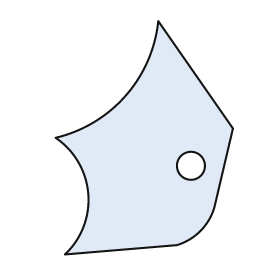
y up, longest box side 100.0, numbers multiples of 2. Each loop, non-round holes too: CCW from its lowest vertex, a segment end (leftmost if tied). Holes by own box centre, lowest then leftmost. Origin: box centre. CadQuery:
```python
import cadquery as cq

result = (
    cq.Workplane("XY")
    .moveTo(-34.0, -50.0)
    .lineTo(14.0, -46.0)
    .threePointArc((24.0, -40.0), (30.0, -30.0))
    .lineTo(38.0, 4.0)
    .lineTo(6.0, 50.0)
    .threePointArc((-8.0, 18.0), (-38.0, 0.0))
    .threePointArc((-24.0, -24.0), (-34.0, -50.0))
    .close()
    .moveTo(20.0, -12.0)
    .circle(6.0)
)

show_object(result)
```